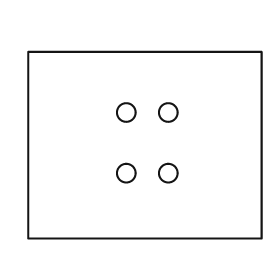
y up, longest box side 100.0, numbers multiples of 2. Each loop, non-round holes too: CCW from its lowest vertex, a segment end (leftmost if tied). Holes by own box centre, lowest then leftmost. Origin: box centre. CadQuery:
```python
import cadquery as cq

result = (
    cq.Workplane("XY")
    .moveTo(-50.0, -40.0)
    .lineTo(50.0, -40.0)
    .lineTo(50.0, 40.0)
    .lineTo(-50.0, 40.0)
    .close()
    .moveTo(-8.0, -12.0)
    .circle(4.0)
    .moveTo(10.0, -12.0)
    .circle(4.0)
    .moveTo(-8.0, 14.0)
    .circle(4.0)
    .moveTo(10.0, 14.0)
    .circle(4.0)
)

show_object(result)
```